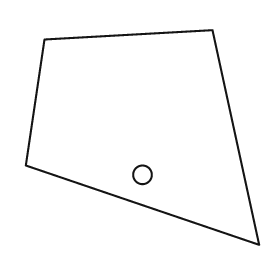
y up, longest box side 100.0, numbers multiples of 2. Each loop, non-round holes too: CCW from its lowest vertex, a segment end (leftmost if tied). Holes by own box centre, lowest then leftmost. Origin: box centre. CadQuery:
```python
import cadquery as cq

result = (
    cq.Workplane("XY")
    .moveTo(50.0, -46.0)
    .lineTo(30.0, 46.0)
    .lineTo(-42.0, 42.0)
    .lineTo(-50.0, -12.0)
    .close()
    .moveTo(0.0, -16.0)
    .circle(4.0)
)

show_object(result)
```